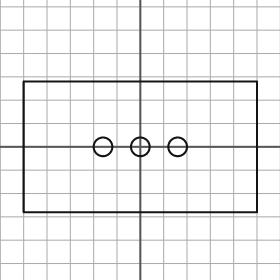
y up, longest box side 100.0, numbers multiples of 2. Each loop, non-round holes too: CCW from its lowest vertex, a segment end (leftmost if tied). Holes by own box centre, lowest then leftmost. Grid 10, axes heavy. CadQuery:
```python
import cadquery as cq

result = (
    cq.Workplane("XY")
    .moveTo(-50.0, -28.0)
    .lineTo(50.0, -28.0)
    .lineTo(50.0, 28.0)
    .lineTo(-50.0, 28.0)
    .close()
    .moveTo(-16.0, 0.0)
    .circle(4.0)
    .moveTo(0.0, 0.0)
    .circle(4.0)
    .moveTo(16.0, 0.0)
    .circle(4.0)
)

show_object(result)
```